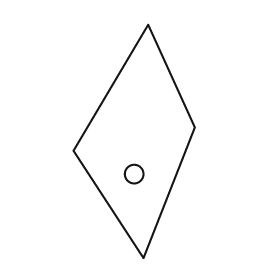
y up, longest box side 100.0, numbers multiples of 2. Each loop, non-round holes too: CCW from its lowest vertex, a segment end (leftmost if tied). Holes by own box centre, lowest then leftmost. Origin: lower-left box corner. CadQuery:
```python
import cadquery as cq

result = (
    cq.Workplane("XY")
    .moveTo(30.0, 0.0)
    .lineTo(52.0, 56.0)
    .lineTo(32.0, 100.0)
    .lineTo(0.0, 46.0)
    .close()
    .moveTo(26.0, 36.0)
    .circle(4.0)
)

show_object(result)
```